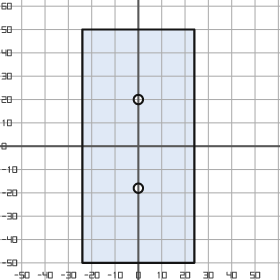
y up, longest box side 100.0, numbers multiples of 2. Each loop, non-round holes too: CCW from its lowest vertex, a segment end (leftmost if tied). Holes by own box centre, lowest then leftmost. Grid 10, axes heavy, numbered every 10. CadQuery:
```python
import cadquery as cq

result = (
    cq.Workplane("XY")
    .moveTo(-24.0, -50.0)
    .lineTo(24.0, -50.0)
    .lineTo(24.0, 50.0)
    .lineTo(-24.0, 50.0)
    .close()
    .moveTo(0.0, -18.0)
    .circle(2.0)
    .moveTo(0.0, 20.0)
    .circle(2.0)
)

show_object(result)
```